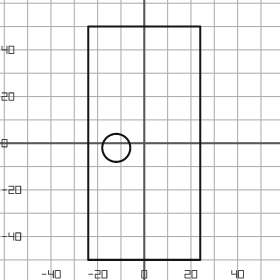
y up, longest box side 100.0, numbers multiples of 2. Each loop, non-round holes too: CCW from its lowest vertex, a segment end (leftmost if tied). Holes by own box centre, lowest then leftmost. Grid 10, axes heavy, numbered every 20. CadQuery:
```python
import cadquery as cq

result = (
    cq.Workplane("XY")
    .moveTo(-24.0, -50.0)
    .lineTo(24.0, -50.0)
    .lineTo(24.0, 50.0)
    .lineTo(-24.0, 50.0)
    .close()
    .moveTo(-12.0, -2.0)
    .circle(6.0)
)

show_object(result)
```